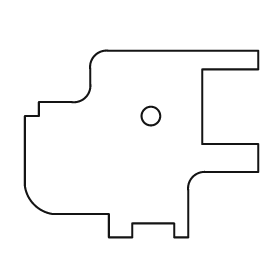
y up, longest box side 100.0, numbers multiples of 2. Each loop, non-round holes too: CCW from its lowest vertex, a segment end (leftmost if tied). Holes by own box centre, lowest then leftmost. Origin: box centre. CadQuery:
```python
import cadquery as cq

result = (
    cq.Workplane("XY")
    .moveTo(-14.0, -40.0)
    .lineTo(-4.0, -40.0)
    .lineTo(-4.0, -34.0)
    .lineTo(14.0, -34.0)
    .lineTo(14.0, -40.0)
    .lineTo(20.0, -40.0)
    .lineTo(20.0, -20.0)
    .threePointArc((22.0, -14.0), (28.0, -12.0))
    .lineTo(50.0, -12.0)
    .lineTo(50.0, 0.0)
    .lineTo(26.0, 0.0)
    .lineTo(26.0, 32.0)
    .lineTo(50.0, 32.0)
    .lineTo(50.0, 40.0)
    .lineTo(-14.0, 40.0)
    .threePointArc((-20.0, 38.0), (-22.0, 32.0))
    .lineTo(-22.0, 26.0)
    .threePointArc((-24.0, 20.0), (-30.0, 18.0))
    .lineTo(-44.0, 18.0)
    .lineTo(-44.0, 12.0)
    .lineTo(-50.0, 12.0)
    .lineTo(-50.0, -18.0)
    .threePointArc((-46.0, -26.0), (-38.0, -30.0))
    .lineTo(-14.0, -30.0)
    .close()
    .moveTo(4.0, 12.0)
    .circle(4.0)
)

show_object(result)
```